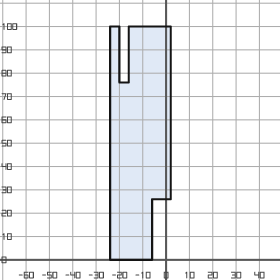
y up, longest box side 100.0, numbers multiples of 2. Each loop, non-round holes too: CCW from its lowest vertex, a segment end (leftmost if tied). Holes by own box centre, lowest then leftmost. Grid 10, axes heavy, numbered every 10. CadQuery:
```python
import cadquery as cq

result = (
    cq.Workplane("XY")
    .moveTo(-24.0, 0.0)
    .lineTo(-6.0, 0.0)
    .lineTo(-6.0, 26.0)
    .lineTo(2.0, 26.0)
    .lineTo(2.0, 100.0)
    .lineTo(-16.0, 100.0)
    .lineTo(-16.0, 76.0)
    .lineTo(-20.0, 76.0)
    .lineTo(-20.0, 100.0)
    .lineTo(-24.0, 100.0)
    .close()
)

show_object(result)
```